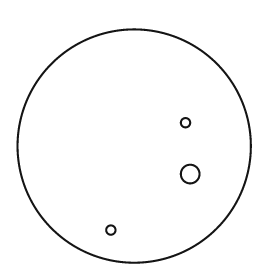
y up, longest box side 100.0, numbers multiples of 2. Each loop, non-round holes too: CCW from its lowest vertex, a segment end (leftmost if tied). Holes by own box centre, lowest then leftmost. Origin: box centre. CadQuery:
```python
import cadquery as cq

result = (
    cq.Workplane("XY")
    .moveTo(0.0, 0.0)
    .circle(50.0)
    .moveTo(-10.0, -36.0)
    .circle(2.0)
    .moveTo(24.0, -12.0)
    .circle(4.0)
    .moveTo(22.0, 10.0)
    .circle(2.0)
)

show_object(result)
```